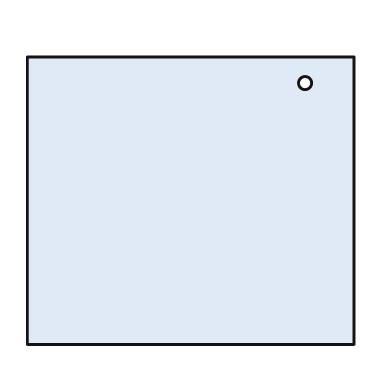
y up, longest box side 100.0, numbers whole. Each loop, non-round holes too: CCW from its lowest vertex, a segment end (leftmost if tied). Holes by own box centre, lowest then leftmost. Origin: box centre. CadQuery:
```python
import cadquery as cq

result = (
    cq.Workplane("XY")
    .moveTo(-50.0, -44.0)
    .lineTo(50.0, -44.0)
    .lineTo(50.0, 44.0)
    .lineTo(-50.0, 44.0)
    .close()
    .moveTo(35.0, 36.0)
    .circle(2.0)
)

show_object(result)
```